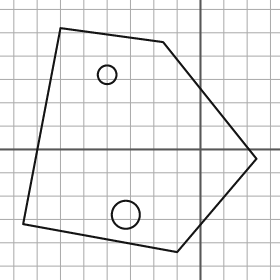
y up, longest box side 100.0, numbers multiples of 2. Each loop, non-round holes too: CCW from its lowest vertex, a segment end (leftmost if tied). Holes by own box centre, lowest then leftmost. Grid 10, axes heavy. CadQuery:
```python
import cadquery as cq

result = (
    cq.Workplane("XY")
    .moveTo(-10.0, -44.0)
    .lineTo(24.0, -4.0)
    .lineTo(-16.0, 46.0)
    .lineTo(-60.0, 52.0)
    .lineTo(-76.0, -32.0)
    .close()
    .moveTo(-32.0, -28.0)
    .circle(6.0)
    .moveTo(-40.0, 32.0)
    .circle(4.0)
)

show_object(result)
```